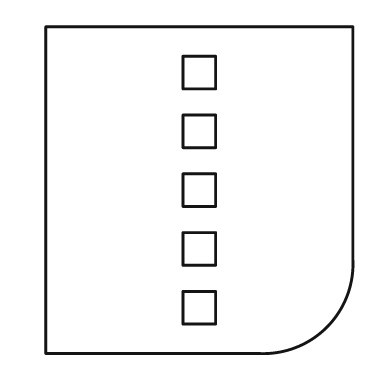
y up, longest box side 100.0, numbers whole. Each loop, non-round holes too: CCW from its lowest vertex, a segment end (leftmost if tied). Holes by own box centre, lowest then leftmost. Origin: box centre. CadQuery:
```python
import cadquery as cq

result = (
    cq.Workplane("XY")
    .moveTo(-47.0, -50.0)
    .lineTo(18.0, -50.0)
    .threePointArc((39.0, -42.0), (47.0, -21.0))
    .lineTo(47.0, 50.0)
    .lineTo(-47.0, 50.0)
    .close()
    .moveTo(-5.0, -41.0)
    .lineTo(5.0, -41.0)
    .lineTo(5.0, -31.0)
    .lineTo(-5.0, -31.0)
    .close()
    .moveTo(-5.0, -23.0)
    .lineTo(5.0, -23.0)
    .lineTo(5.0, -13.0)
    .lineTo(-5.0, -13.0)
    .close()
    .moveTo(-5.0, -5.0)
    .lineTo(5.0, -5.0)
    .lineTo(5.0, 5.0)
    .lineTo(-5.0, 5.0)
    .close()
    .moveTo(-5.0, 13.0)
    .lineTo(5.0, 13.0)
    .lineTo(5.0, 23.0)
    .lineTo(-5.0, 23.0)
    .close()
    .moveTo(-5.0, 31.0)
    .lineTo(5.0, 31.0)
    .lineTo(5.0, 41.0)
    .lineTo(-5.0, 41.0)
    .close()
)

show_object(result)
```